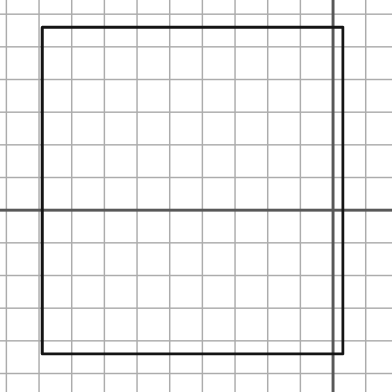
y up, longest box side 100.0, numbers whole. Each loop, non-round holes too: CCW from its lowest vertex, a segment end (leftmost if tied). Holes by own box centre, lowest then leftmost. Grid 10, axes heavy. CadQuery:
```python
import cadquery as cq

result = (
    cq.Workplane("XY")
    .moveTo(-89.0, -44.0)
    .lineTo(3.0, -44.0)
    .lineTo(3.0, 56.0)
    .lineTo(-89.0, 56.0)
    .close()
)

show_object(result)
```